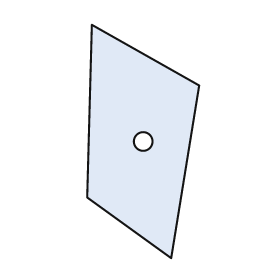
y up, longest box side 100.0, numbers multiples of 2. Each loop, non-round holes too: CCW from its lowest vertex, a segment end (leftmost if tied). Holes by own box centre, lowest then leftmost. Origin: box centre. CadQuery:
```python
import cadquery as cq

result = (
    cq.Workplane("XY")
    .moveTo(12.0, -50.0)
    .lineTo(24.0, 24.0)
    .lineTo(-22.0, 50.0)
    .lineTo(-24.0, -24.0)
    .close()
    .moveTo(0.0, 0.0)
    .circle(4.0)
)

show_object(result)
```